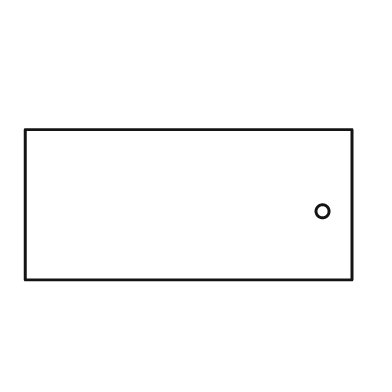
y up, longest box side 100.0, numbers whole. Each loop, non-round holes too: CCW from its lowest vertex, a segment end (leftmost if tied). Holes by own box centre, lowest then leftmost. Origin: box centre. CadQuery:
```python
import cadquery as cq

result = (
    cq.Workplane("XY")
    .moveTo(-50.0, -23.0)
    .lineTo(50.0, -23.0)
    .lineTo(50.0, 23.0)
    .lineTo(-50.0, 23.0)
    .close()
    .moveTo(41.0, -2.0)
    .circle(2.0)
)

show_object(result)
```